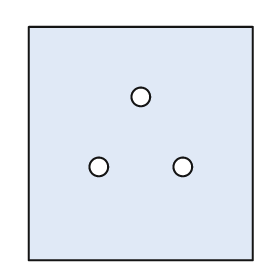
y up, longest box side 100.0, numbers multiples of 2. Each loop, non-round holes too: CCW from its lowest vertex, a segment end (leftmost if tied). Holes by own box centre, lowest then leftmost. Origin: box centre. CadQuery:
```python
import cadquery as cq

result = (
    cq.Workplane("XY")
    .moveTo(-48.0, -50.0)
    .lineTo(48.0, -50.0)
    .lineTo(48.0, 50.0)
    .lineTo(-48.0, 50.0)
    .close()
    .moveTo(-18.0, -10.0)
    .circle(4.0)
    .moveTo(18.0, -10.0)
    .circle(4.0)
    .moveTo(0.0, 20.0)
    .circle(4.0)
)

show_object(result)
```